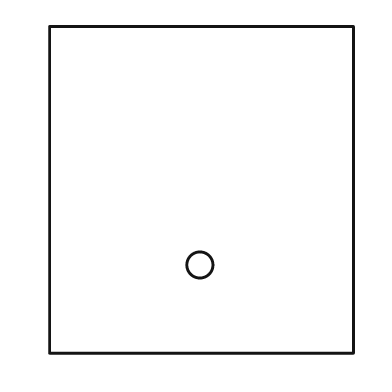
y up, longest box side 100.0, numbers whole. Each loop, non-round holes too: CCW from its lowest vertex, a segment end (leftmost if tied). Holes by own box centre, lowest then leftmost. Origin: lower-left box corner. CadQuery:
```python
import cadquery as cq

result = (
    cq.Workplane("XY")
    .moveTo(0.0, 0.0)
    .lineTo(93.0, 0.0)
    .lineTo(93.0, 100.0)
    .lineTo(0.0, 100.0)
    .close()
    .moveTo(46.0, 27.0)
    .circle(4.0)
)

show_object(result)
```